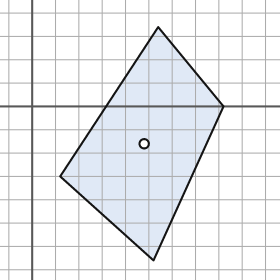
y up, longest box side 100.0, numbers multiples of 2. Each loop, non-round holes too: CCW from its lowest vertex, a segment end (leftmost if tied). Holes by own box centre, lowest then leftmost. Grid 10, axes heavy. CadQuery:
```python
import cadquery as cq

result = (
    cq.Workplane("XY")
    .moveTo(52.0, -66.0)
    .lineTo(82.0, 0.0)
    .lineTo(54.0, 34.0)
    .lineTo(12.0, -30.0)
    .close()
    .moveTo(48.0, -16.0)
    .circle(2.0)
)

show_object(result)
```